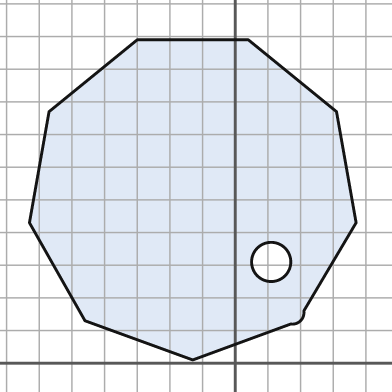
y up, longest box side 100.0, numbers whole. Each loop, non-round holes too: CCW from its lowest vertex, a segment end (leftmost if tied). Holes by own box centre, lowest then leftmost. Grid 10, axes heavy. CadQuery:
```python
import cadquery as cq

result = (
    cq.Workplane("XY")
    .moveTo(-13.0, 1.0)
    .lineTo(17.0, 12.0)
    .threePointArc((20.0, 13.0), (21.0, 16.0))
    .lineTo(37.0, 43.0)
    .lineTo(31.0, 77.0)
    .lineTo(4.0, 99.0)
    .lineTo(-30.0, 99.0)
    .lineTo(-57.0, 77.0)
    .lineTo(-63.0, 43.0)
    .lineTo(-46.0, 13.0)
    .close()
    .moveTo(11.0, 31.0)
    .circle(6.0)
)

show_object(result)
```